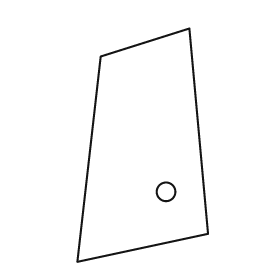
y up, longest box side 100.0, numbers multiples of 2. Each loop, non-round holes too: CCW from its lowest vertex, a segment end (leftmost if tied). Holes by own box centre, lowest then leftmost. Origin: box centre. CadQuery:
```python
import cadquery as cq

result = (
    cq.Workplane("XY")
    .moveTo(-28.0, -50.0)
    .lineTo(28.0, -38.0)
    .lineTo(20.0, 50.0)
    .lineTo(-18.0, 38.0)
    .close()
    .moveTo(10.0, -20.0)
    .circle(4.0)
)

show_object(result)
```